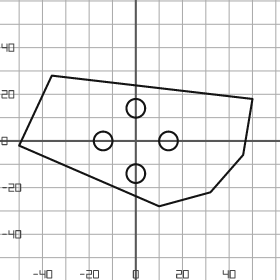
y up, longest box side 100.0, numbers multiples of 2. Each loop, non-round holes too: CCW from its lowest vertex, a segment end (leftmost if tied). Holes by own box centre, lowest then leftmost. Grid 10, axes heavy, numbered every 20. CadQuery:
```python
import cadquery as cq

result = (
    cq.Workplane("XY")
    .moveTo(10.0, -28.0)
    .lineTo(32.0, -22.0)
    .lineTo(46.0, -6.0)
    .lineTo(50.0, 18.0)
    .lineTo(-36.0, 28.0)
    .lineTo(-50.0, -2.0)
    .close()
    .moveTo(0.0, -14.0)
    .circle(4.0)
    .moveTo(-14.0, 0.0)
    .circle(4.0)
    .moveTo(14.0, 0.0)
    .circle(4.0)
    .moveTo(0.0, 14.0)
    .circle(4.0)
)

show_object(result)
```